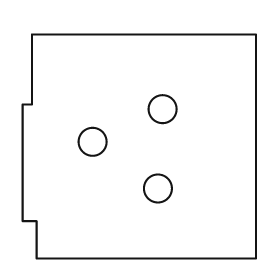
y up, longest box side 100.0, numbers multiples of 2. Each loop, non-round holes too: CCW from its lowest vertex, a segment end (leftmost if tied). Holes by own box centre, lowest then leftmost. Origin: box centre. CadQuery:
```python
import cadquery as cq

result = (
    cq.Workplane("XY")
    .moveTo(-44.0, -48.0)
    .lineTo(50.0, -48.0)
    .lineTo(50.0, 48.0)
    .lineTo(-46.0, 48.0)
    .lineTo(-46.0, 18.0)
    .lineTo(-50.0, 18.0)
    .lineTo(-50.0, -32.0)
    .lineTo(-44.0, -32.0)
    .close()
    .moveTo(8.0, -18.0)
    .circle(6.0)
    .moveTo(-20.0, 2.0)
    .circle(6.0)
    .moveTo(10.0, 16.0)
    .circle(6.0)
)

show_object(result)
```